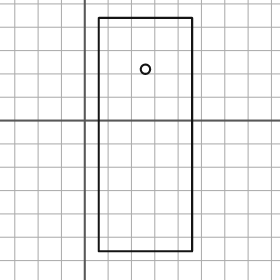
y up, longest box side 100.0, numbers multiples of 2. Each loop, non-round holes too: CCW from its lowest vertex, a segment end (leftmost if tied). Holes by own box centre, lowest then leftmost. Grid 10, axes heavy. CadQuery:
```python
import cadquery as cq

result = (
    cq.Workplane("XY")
    .moveTo(6.0, -56.0)
    .lineTo(46.0, -56.0)
    .lineTo(46.0, 44.0)
    .lineTo(6.0, 44.0)
    .close()
    .moveTo(26.0, 22.0)
    .circle(2.0)
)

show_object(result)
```